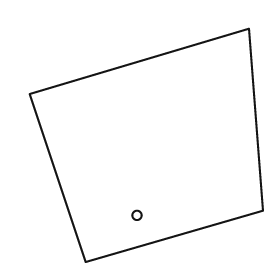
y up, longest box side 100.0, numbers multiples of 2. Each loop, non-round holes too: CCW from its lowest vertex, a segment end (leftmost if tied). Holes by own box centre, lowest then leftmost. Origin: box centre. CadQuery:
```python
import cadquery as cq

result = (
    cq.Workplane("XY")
    .moveTo(-26.0, -50.0)
    .lineTo(50.0, -28.0)
    .lineTo(44.0, 50.0)
    .lineTo(-50.0, 22.0)
    .close()
    .moveTo(-4.0, -30.0)
    .circle(2.0)
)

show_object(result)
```